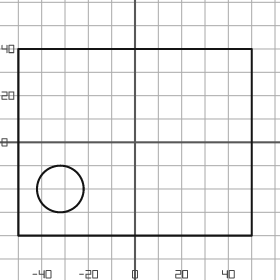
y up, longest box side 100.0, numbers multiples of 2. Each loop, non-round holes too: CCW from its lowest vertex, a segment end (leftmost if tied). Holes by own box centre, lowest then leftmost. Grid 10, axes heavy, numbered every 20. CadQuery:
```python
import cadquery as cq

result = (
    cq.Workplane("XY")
    .moveTo(-50.0, -40.0)
    .lineTo(50.0, -40.0)
    .lineTo(50.0, 40.0)
    .lineTo(-50.0, 40.0)
    .close()
    .moveTo(-32.0, -20.0)
    .circle(10.0)
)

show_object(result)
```